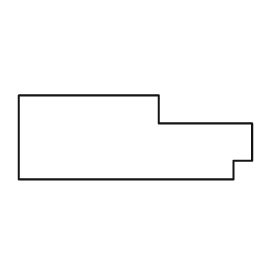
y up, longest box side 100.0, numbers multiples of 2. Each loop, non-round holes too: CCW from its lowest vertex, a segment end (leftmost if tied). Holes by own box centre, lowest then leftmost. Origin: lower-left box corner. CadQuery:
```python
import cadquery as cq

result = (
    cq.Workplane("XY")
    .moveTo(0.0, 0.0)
    .lineTo(92.0, 0.0)
    .lineTo(92.0, 8.0)
    .lineTo(100.0, 8.0)
    .lineTo(100.0, 24.0)
    .lineTo(60.0, 24.0)
    .lineTo(60.0, 36.0)
    .lineTo(0.0, 36.0)
    .close()
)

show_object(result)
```